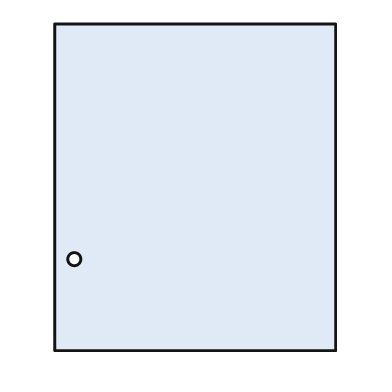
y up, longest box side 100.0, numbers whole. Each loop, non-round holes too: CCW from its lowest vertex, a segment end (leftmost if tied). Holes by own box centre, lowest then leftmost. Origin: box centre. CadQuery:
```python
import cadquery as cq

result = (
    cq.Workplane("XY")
    .moveTo(-43.0, -50.0)
    .lineTo(43.0, -50.0)
    .lineTo(43.0, 50.0)
    .lineTo(-43.0, 50.0)
    .close()
    .moveTo(-37.0, -22.0)
    .circle(2.0)
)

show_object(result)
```